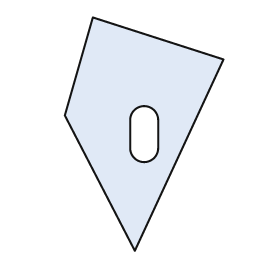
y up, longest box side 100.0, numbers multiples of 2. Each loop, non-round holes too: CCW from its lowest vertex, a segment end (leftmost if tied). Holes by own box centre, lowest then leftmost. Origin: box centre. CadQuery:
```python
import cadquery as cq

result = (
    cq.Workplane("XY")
    .moveTo(-4.0, -50.0)
    .lineTo(34.0, 32.0)
    .lineTo(-22.0, 50.0)
    .lineTo(-34.0, 8.0)
    .close()
    .moveTo(-6.0, -6.0)
    .threePointArc((0.0, -12.0), (6.0, -6.0))
    .lineTo(6.0, 6.0)
    .threePointArc((0.0, 12.0), (-6.0, 6.0))
    .close()
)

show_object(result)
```